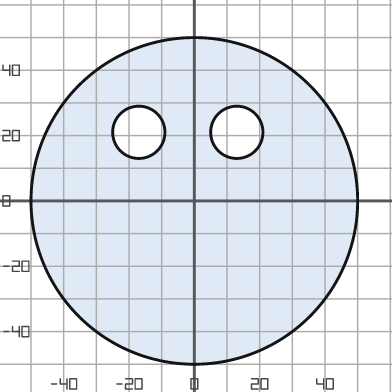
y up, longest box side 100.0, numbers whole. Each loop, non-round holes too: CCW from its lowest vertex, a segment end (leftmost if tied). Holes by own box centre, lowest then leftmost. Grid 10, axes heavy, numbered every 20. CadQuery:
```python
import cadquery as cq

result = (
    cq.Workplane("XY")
    .moveTo(0.0, 0.0)
    .circle(50.0)
    .moveTo(-17.0, 21.0)
    .circle(8.0)
    .moveTo(13.0, 21.0)
    .circle(8.0)
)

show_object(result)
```